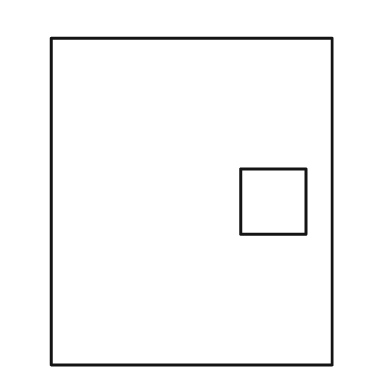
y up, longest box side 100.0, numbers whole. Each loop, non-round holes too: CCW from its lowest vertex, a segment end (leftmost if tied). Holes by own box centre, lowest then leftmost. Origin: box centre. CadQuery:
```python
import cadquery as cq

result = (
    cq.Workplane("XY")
    .moveTo(-43.0, -50.0)
    .lineTo(43.0, -50.0)
    .lineTo(43.0, 50.0)
    .lineTo(-43.0, 50.0)
    .close()
    .moveTo(15.0, -10.0)
    .lineTo(35.0, -10.0)
    .lineTo(35.0, 10.0)
    .lineTo(15.0, 10.0)
    .close()
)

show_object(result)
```